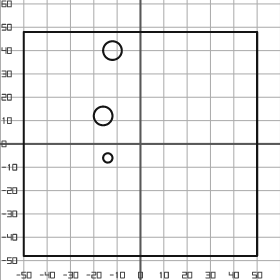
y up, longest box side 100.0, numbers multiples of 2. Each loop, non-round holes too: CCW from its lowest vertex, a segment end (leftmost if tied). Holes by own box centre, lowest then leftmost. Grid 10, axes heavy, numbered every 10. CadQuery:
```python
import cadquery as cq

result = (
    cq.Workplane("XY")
    .moveTo(-50.0, -48.0)
    .lineTo(50.0, -48.0)
    .lineTo(50.0, 48.0)
    .lineTo(-50.0, 48.0)
    .close()
    .moveTo(-14.0, -6.0)
    .circle(2.0)
    .moveTo(-16.0, 12.0)
    .circle(4.0)
    .moveTo(-12.0, 40.0)
    .circle(4.0)
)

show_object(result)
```